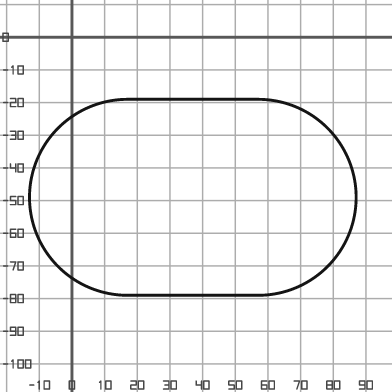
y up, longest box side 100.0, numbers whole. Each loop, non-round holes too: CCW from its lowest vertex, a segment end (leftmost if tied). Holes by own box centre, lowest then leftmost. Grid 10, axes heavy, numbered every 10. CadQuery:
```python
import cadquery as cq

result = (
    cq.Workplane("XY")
    .moveTo(17.0, -79.0)
    .lineTo(57.0, -79.0)
    .threePointArc((87.0, -49.0), (57.0, -19.0))
    .lineTo(17.0, -19.0)
    .threePointArc((-13.0, -49.0), (17.0, -79.0))
    .close()
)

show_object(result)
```